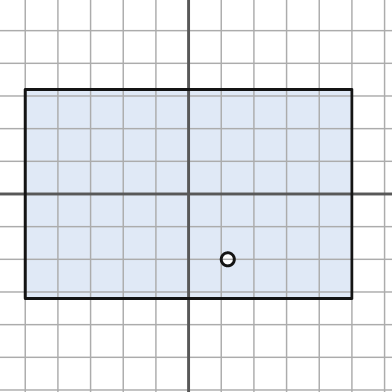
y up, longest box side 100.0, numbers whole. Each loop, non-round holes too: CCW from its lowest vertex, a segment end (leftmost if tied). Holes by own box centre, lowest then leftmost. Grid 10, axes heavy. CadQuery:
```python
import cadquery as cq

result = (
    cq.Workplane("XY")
    .moveTo(-50.0, -32.0)
    .lineTo(50.0, -32.0)
    .lineTo(50.0, 32.0)
    .lineTo(-50.0, 32.0)
    .close()
    .moveTo(12.0, -20.0)
    .circle(2.0)
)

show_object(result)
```